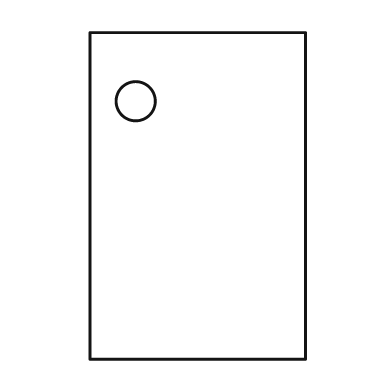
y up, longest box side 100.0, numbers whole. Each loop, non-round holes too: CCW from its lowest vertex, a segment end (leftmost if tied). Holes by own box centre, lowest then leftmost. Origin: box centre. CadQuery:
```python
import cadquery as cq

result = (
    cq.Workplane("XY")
    .moveTo(-33.0, -50.0)
    .lineTo(33.0, -50.0)
    .lineTo(33.0, 50.0)
    .lineTo(-33.0, 50.0)
    .close()
    .moveTo(-19.0, 29.0)
    .circle(6.0)
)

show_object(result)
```